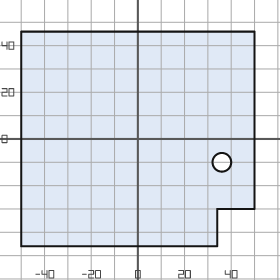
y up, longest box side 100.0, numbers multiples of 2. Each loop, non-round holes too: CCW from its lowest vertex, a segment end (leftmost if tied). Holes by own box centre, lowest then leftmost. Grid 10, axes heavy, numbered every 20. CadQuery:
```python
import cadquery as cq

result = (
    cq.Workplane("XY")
    .moveTo(-50.0, -46.0)
    .lineTo(34.0, -46.0)
    .lineTo(34.0, -30.0)
    .lineTo(50.0, -30.0)
    .lineTo(50.0, 46.0)
    .lineTo(-50.0, 46.0)
    .close()
    .moveTo(36.0, -10.0)
    .circle(4.0)
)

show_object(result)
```